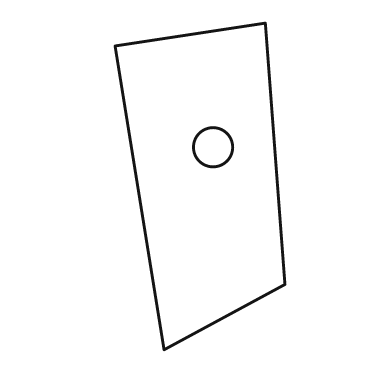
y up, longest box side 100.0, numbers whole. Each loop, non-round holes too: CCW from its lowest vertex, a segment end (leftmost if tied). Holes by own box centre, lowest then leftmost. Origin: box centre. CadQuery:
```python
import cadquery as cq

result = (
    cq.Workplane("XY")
    .moveTo(-11.0, -50.0)
    .lineTo(26.0, -30.0)
    .lineTo(20.0, 50.0)
    .lineTo(-26.0, 43.0)
    .close()
    .moveTo(4.0, 12.0)
    .circle(6.0)
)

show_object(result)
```